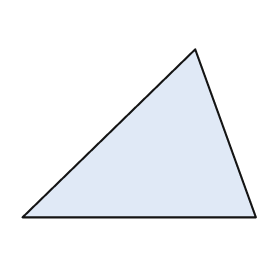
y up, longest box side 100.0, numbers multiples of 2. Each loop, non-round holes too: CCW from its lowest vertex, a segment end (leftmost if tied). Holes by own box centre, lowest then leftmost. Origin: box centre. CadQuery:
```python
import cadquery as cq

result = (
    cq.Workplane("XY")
    .moveTo(-50.0, -36.0)
    .lineTo(50.0, -36.0)
    .lineTo(24.0, 36.0)
    .close()
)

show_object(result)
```